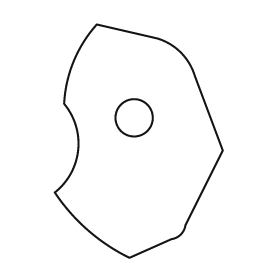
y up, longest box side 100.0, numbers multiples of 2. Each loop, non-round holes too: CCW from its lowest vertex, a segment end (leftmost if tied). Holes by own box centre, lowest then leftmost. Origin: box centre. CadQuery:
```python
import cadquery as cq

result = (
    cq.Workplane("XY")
    .moveTo(-4.0, -50.0)
    .lineTo(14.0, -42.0)
    .threePointArc((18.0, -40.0), (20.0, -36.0))
    .lineTo(36.0, -4.0)
    .lineTo(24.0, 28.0)
    .threePointArc((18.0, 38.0), (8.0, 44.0))
    .lineTo(-18.0, 50.0)
    .threePointArc((-28.0, 34.0), (-32.0, 16.0))
    .threePointArc((-26.0, -4.0), (-36.0, -22.0))
    .threePointArc((-22.0, -38.0), (-4.0, -50.0))
    .close()
    .moveTo(-2.0, 10.0)
    .circle(8.0)
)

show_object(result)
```